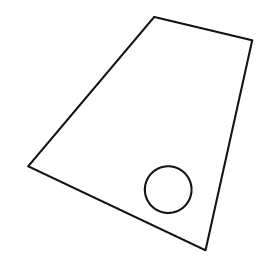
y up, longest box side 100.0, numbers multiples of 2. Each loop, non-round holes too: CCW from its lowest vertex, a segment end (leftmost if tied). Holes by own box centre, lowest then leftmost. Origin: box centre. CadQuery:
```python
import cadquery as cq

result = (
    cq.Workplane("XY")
    .moveTo(28.0, -50.0)
    .lineTo(48.0, 40.0)
    .lineTo(6.0, 50.0)
    .lineTo(-48.0, -14.0)
    .close()
    .moveTo(12.0, -24.0)
    .circle(10.0)
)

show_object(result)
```